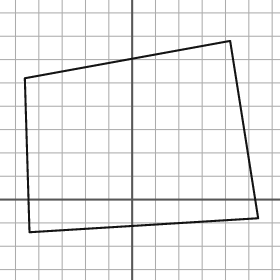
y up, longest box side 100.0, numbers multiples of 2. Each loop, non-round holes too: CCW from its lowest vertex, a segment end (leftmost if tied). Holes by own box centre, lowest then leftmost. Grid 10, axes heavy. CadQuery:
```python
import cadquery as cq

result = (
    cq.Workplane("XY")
    .moveTo(-44.0, -14.0)
    .lineTo(54.0, -8.0)
    .lineTo(42.0, 68.0)
    .lineTo(-46.0, 52.0)
    .close()
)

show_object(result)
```